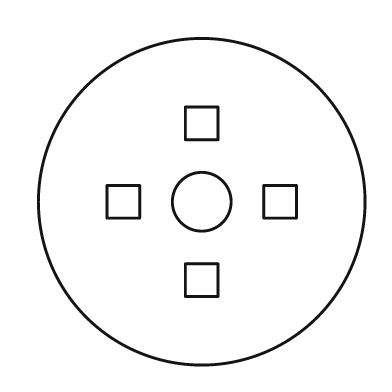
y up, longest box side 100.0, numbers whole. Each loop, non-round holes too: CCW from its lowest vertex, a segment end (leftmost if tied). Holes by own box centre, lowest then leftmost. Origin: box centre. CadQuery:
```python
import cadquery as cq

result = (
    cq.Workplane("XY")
    .moveTo(0.0, 0.0)
    .circle(50.0)
    .moveTo(-5.0, -29.0)
    .lineTo(5.0, -29.0)
    .lineTo(5.0, -19.0)
    .lineTo(-5.0, -19.0)
    .close()
    .moveTo(-29.0, -5.0)
    .lineTo(-19.0, -5.0)
    .lineTo(-19.0, 5.0)
    .lineTo(-29.0, 5.0)
    .close()
    .moveTo(0.0, 0.0)
    .circle(9.0)
    .moveTo(19.0, -5.0)
    .lineTo(29.0, -5.0)
    .lineTo(29.0, 5.0)
    .lineTo(19.0, 5.0)
    .close()
    .moveTo(-5.0, 19.0)
    .lineTo(5.0, 19.0)
    .lineTo(5.0, 29.0)
    .lineTo(-5.0, 29.0)
    .close()
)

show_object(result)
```